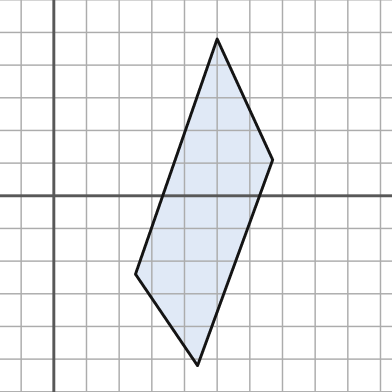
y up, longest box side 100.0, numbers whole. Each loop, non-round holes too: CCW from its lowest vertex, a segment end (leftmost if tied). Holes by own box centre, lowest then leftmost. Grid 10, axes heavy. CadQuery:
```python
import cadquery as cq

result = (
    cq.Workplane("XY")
    .moveTo(44.0, -52.0)
    .lineTo(67.0, 11.0)
    .lineTo(50.0, 48.0)
    .lineTo(25.0, -24.0)
    .close()
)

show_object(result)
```